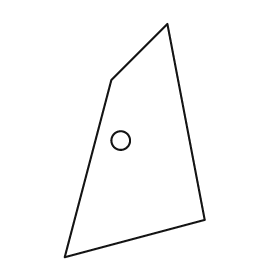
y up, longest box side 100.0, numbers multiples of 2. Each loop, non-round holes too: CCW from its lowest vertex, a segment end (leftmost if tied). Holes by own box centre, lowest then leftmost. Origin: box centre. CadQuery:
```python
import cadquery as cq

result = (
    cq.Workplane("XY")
    .moveTo(-30.0, -50.0)
    .lineTo(30.0, -34.0)
    .lineTo(14.0, 50.0)
    .lineTo(-10.0, 26.0)
    .close()
    .moveTo(-6.0, 0.0)
    .circle(4.0)
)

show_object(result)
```